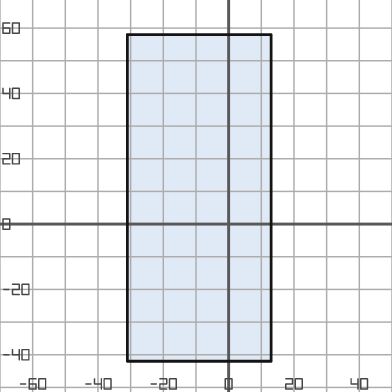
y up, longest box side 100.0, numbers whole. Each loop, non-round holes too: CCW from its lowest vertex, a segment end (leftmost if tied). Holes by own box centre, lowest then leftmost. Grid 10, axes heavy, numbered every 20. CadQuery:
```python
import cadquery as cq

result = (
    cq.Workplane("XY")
    .moveTo(-31.0, -42.0)
    .lineTo(13.0, -42.0)
    .lineTo(13.0, 58.0)
    .lineTo(-31.0, 58.0)
    .close()
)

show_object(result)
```